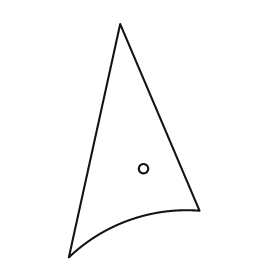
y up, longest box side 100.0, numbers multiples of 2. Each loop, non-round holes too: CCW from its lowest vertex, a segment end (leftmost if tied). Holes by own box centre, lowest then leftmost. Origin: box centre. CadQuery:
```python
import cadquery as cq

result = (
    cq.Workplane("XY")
    .moveTo(-28.0, -50.0)
    .threePointArc((-2.0, -34.0), (28.0, -30.0))
    .lineTo(-6.0, 50.0)
    .close()
    .moveTo(4.0, -12.0)
    .circle(2.0)
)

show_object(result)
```